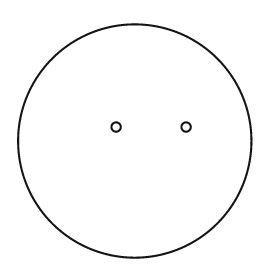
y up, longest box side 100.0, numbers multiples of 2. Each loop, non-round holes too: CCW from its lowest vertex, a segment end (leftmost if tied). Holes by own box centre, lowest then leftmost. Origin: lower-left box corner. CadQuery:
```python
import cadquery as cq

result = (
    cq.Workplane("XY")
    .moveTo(50.0, 50.0)
    .circle(50.0)
    .moveTo(42.0, 56.0)
    .circle(2.0)
    .moveTo(72.0, 56.0)
    .circle(2.0)
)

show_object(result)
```